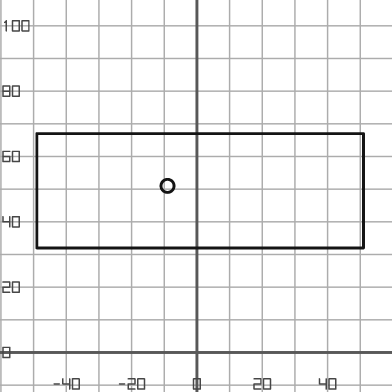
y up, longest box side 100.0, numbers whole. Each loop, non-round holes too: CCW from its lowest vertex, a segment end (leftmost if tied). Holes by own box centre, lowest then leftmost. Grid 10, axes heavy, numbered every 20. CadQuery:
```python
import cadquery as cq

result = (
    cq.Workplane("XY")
    .moveTo(-49.0, 32.0)
    .lineTo(51.0, 32.0)
    .lineTo(51.0, 67.0)
    .lineTo(-49.0, 67.0)
    .close()
    .moveTo(-9.0, 51.0)
    .circle(2.0)
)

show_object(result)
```